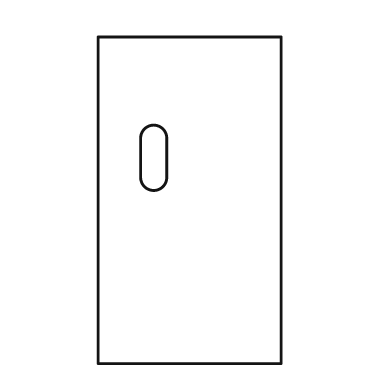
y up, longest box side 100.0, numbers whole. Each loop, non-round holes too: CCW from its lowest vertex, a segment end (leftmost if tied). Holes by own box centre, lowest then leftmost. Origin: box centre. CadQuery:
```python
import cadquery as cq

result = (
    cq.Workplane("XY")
    .moveTo(-28.0, -50.0)
    .lineTo(28.0, -50.0)
    .lineTo(28.0, 50.0)
    .lineTo(-28.0, 50.0)
    .close()
    .moveTo(-15.0, 7.0)
    .threePointArc((-11.0, 3.0), (-7.0, 7.0))
    .lineTo(-7.0, 19.0)
    .threePointArc((-11.0, 23.0), (-15.0, 19.0))
    .close()
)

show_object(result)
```